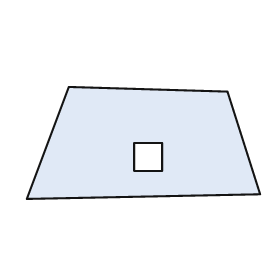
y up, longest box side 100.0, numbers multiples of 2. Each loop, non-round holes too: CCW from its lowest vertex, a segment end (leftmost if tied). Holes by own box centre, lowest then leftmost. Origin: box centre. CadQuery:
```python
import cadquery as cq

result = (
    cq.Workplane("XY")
    .moveTo(-50.0, -24.0)
    .lineTo(50.0, -22.0)
    .lineTo(36.0, 22.0)
    .lineTo(-32.0, 24.0)
    .close()
    .moveTo(-4.0, -12.0)
    .lineTo(8.0, -12.0)
    .lineTo(8.0, 0.0)
    .lineTo(-4.0, 0.0)
    .close()
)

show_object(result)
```